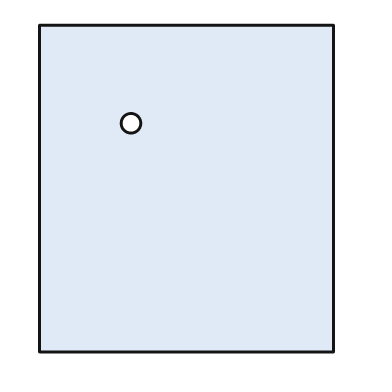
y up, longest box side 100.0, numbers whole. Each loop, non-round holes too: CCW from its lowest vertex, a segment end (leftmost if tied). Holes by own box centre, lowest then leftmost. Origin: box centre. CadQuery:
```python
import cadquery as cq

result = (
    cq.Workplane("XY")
    .moveTo(-45.0, -50.0)
    .lineTo(45.0, -50.0)
    .lineTo(45.0, 50.0)
    .lineTo(-45.0, 50.0)
    .close()
    .moveTo(-17.0, 20.0)
    .circle(3.0)
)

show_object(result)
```